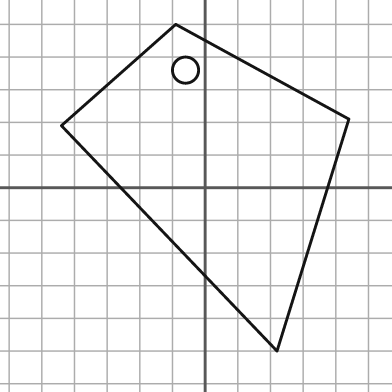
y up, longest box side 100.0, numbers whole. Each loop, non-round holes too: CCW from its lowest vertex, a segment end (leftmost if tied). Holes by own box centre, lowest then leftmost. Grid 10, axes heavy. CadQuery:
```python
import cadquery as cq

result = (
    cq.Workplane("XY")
    .moveTo(22.0, -50.0)
    .lineTo(44.0, 21.0)
    .lineTo(-9.0, 50.0)
    .lineTo(-44.0, 19.0)
    .close()
    .moveTo(-6.0, 36.0)
    .circle(4.0)
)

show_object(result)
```